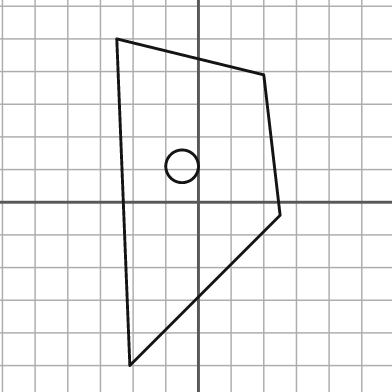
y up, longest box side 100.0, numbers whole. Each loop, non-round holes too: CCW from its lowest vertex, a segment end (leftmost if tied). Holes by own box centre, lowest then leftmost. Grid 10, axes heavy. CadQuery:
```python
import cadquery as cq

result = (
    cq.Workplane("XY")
    .moveTo(-21.0, -50.0)
    .lineTo(25.0, -4.0)
    .lineTo(20.0, 39.0)
    .lineTo(-25.0, 50.0)
    .close()
    .moveTo(-5.0, 11.0)
    .circle(5.0)
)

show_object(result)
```